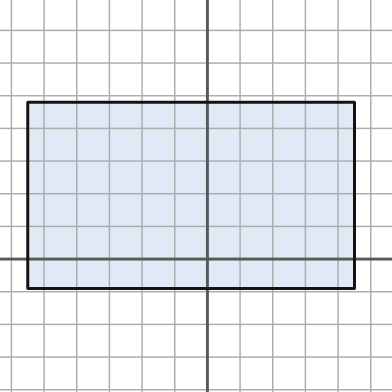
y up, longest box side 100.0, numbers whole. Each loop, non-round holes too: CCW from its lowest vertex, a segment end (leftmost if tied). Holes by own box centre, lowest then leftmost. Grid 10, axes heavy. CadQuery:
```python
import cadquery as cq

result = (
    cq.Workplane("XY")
    .moveTo(-55.0, -9.0)
    .lineTo(45.0, -9.0)
    .lineTo(45.0, 48.0)
    .lineTo(-55.0, 48.0)
    .close()
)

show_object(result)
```